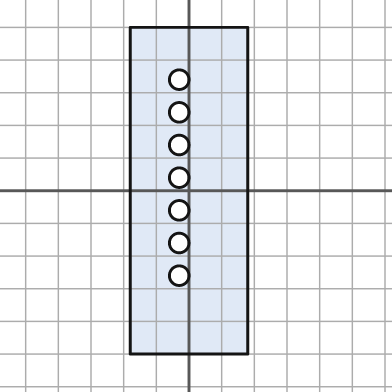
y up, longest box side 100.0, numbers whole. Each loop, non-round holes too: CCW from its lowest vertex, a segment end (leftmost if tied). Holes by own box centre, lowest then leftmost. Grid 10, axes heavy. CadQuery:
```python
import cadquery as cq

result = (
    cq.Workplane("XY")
    .moveTo(-18.0, -50.0)
    .lineTo(18.0, -50.0)
    .lineTo(18.0, 50.0)
    .lineTo(-18.0, 50.0)
    .close()
    .moveTo(-3.0, -26.0)
    .circle(3.0)
    .moveTo(-3.0, -16.0)
    .circle(3.0)
    .moveTo(-3.0, -6.0)
    .circle(3.0)
    .moveTo(-3.0, 4.0)
    .circle(3.0)
    .moveTo(-3.0, 14.0)
    .circle(3.0)
    .moveTo(-3.0, 24.0)
    .circle(3.0)
    .moveTo(-3.0, 34.0)
    .circle(3.0)
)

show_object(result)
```